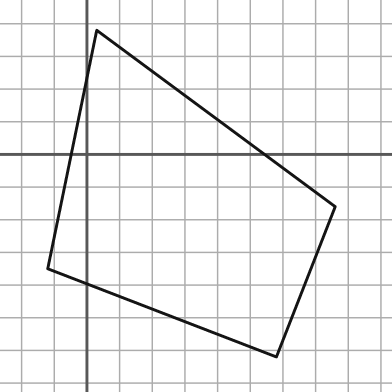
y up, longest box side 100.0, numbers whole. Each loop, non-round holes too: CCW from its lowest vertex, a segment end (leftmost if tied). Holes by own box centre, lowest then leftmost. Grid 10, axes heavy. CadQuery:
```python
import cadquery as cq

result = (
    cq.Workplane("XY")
    .moveTo(58.0, -62.0)
    .lineTo(76.0, -16.0)
    .lineTo(3.0, 38.0)
    .lineTo(-12.0, -35.0)
    .close()
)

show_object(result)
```